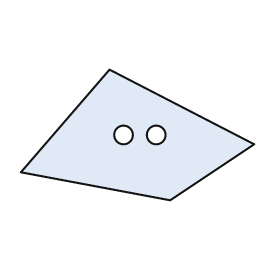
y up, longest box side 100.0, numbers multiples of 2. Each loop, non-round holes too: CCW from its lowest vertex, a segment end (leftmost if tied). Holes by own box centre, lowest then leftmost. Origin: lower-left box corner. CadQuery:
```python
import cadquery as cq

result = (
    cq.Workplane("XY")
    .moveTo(64.0, 0.0)
    .lineTo(100.0, 24.0)
    .lineTo(38.0, 56.0)
    .lineTo(0.0, 12.0)
    .close()
    .moveTo(44.0, 28.0)
    .circle(4.0)
    .moveTo(58.0, 28.0)
    .circle(4.0)
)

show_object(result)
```